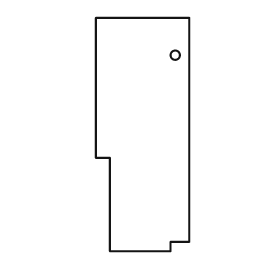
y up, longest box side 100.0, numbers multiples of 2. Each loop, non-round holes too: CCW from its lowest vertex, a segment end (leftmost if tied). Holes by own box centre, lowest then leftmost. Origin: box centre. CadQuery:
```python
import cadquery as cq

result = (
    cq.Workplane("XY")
    .moveTo(-14.0, -50.0)
    .lineTo(12.0, -50.0)
    .lineTo(12.0, -46.0)
    .lineTo(20.0, -46.0)
    .lineTo(20.0, 50.0)
    .lineTo(-20.0, 50.0)
    .lineTo(-20.0, -10.0)
    .lineTo(-14.0, -10.0)
    .close()
    .moveTo(14.0, 34.0)
    .circle(2.0)
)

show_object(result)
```